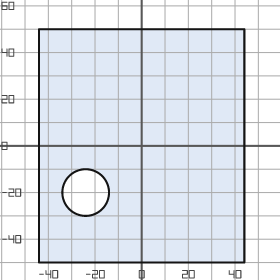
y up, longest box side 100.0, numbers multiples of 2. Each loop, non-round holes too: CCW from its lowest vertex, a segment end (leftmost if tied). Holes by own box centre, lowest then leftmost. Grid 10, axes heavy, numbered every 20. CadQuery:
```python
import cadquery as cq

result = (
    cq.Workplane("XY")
    .moveTo(-44.0, -50.0)
    .lineTo(44.0, -50.0)
    .lineTo(44.0, 50.0)
    .lineTo(-44.0, 50.0)
    .close()
    .moveTo(-24.0, -20.0)
    .circle(10.0)
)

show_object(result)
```